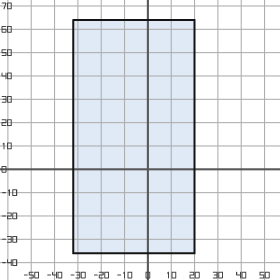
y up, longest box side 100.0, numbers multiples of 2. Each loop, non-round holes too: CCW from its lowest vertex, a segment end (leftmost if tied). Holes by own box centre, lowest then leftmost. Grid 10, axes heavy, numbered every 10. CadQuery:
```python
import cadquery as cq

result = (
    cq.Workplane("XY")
    .moveTo(-32.0, -36.0)
    .lineTo(20.0, -36.0)
    .lineTo(20.0, 64.0)
    .lineTo(-32.0, 64.0)
    .close()
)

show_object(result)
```